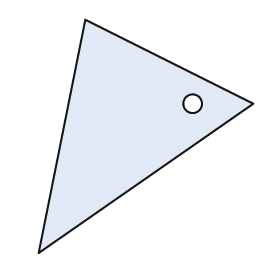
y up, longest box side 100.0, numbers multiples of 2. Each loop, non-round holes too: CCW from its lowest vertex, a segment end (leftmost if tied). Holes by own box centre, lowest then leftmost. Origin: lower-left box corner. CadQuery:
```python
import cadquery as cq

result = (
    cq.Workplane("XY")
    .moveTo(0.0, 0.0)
    .lineTo(92.0, 64.0)
    .lineTo(20.0, 100.0)
    .close()
    .moveTo(66.0, 64.0)
    .circle(4.0)
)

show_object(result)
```